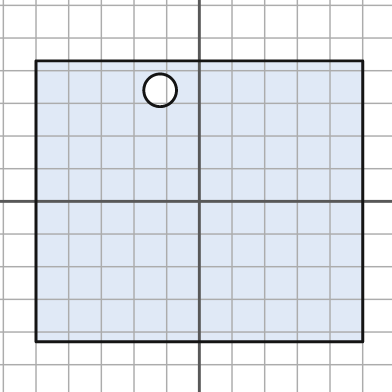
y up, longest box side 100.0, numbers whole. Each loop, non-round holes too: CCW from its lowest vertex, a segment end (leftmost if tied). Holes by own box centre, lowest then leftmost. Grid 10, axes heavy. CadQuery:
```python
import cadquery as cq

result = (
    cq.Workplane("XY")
    .moveTo(-50.0, -43.0)
    .lineTo(50.0, -43.0)
    .lineTo(50.0, 43.0)
    .lineTo(-50.0, 43.0)
    .close()
    .moveTo(-12.0, 34.0)
    .circle(5.0)
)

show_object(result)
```